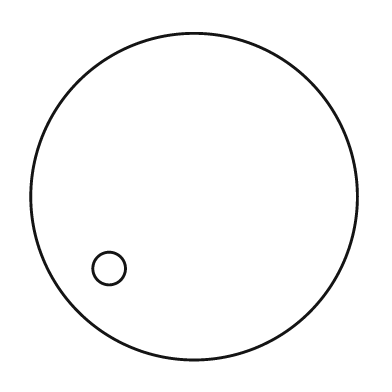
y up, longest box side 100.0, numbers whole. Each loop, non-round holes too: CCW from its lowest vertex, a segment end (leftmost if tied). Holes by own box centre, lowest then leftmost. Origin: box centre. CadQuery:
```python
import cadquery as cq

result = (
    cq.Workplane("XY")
    .moveTo(0.0, 0.0)
    .circle(50.0)
    .moveTo(-26.0, -22.0)
    .circle(5.0)
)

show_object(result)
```